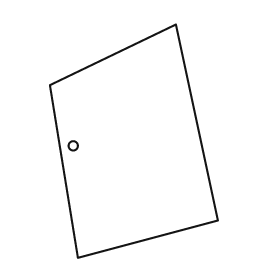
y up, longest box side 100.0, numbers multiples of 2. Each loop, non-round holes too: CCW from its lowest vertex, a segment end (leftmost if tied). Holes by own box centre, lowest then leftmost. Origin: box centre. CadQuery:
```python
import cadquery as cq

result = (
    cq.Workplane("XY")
    .moveTo(-24.0, -50.0)
    .lineTo(36.0, -34.0)
    .lineTo(18.0, 50.0)
    .lineTo(-36.0, 24.0)
    .close()
    .moveTo(-26.0, -2.0)
    .circle(2.0)
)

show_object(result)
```